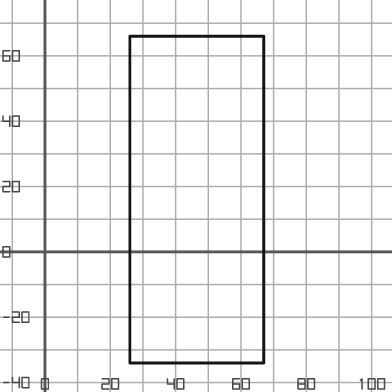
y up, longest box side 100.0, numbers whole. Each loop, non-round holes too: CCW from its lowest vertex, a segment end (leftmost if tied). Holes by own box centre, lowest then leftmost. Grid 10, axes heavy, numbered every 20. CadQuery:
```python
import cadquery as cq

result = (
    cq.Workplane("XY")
    .moveTo(26.0, -34.0)
    .lineTo(67.0, -34.0)
    .lineTo(67.0, 66.0)
    .lineTo(26.0, 66.0)
    .close()
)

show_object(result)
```